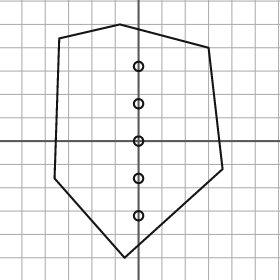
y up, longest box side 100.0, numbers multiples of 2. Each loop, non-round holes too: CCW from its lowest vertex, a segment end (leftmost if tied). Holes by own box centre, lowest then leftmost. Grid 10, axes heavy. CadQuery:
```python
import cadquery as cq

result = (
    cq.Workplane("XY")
    .moveTo(-6.0, -50.0)
    .lineTo(36.0, -12.0)
    .lineTo(30.0, 40.0)
    .lineTo(-8.0, 50.0)
    .lineTo(-34.0, 44.0)
    .lineTo(-36.0, -16.0)
    .close()
    .moveTo(0.0, -32.0)
    .circle(2.0)
    .moveTo(0.0, -16.0)
    .circle(2.0)
    .moveTo(0.0, 0.0)
    .circle(2.0)
    .moveTo(0.0, 16.0)
    .circle(2.0)
    .moveTo(0.0, 32.0)
    .circle(2.0)
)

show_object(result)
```